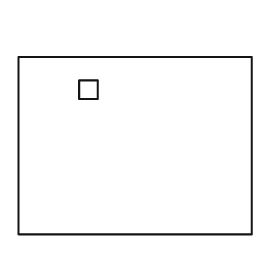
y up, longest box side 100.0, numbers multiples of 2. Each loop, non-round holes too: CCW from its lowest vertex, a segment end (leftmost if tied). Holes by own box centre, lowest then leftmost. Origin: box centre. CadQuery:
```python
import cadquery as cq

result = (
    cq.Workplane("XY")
    .moveTo(-50.0, -38.0)
    .lineTo(50.0, -38.0)
    .lineTo(50.0, 38.0)
    .lineTo(-50.0, 38.0)
    .close()
    .moveTo(-24.0, 20.0)
    .lineTo(-16.0, 20.0)
    .lineTo(-16.0, 28.0)
    .lineTo(-24.0, 28.0)
    .close()
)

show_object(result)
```